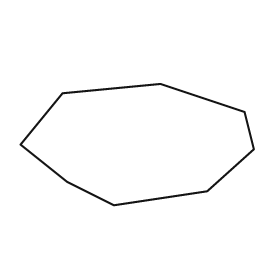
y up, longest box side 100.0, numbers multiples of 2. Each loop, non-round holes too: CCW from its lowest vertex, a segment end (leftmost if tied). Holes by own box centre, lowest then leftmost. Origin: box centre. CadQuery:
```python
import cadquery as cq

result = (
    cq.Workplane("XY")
    .moveTo(-10.0, -26.0)
    .lineTo(30.0, -20.0)
    .lineTo(50.0, -2.0)
    .lineTo(46.0, 14.0)
    .lineTo(10.0, 26.0)
    .lineTo(-32.0, 22.0)
    .lineTo(-50.0, 0.0)
    .lineTo(-30.0, -16.0)
    .close()
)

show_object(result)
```